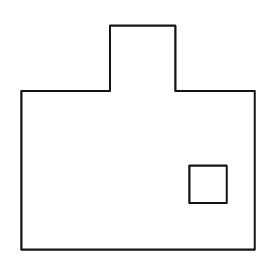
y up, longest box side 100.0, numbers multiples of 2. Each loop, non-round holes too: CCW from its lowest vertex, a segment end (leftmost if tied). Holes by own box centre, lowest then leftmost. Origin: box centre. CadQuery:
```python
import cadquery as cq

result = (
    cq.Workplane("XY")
    .moveTo(-50.0, -48.0)
    .lineTo(50.0, -48.0)
    .lineTo(50.0, 20.0)
    .lineTo(16.0, 20.0)
    .lineTo(16.0, 48.0)
    .lineTo(-12.0, 48.0)
    .lineTo(-12.0, 20.0)
    .lineTo(-50.0, 20.0)
    .close()
    .moveTo(22.0, -28.0)
    .lineTo(38.0, -28.0)
    .lineTo(38.0, -12.0)
    .lineTo(22.0, -12.0)
    .close()
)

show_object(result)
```